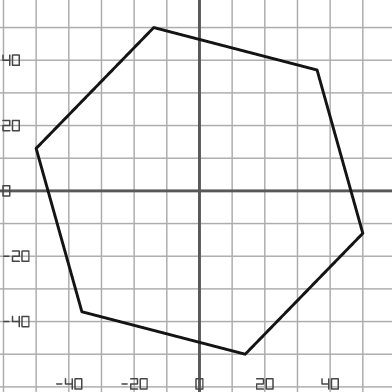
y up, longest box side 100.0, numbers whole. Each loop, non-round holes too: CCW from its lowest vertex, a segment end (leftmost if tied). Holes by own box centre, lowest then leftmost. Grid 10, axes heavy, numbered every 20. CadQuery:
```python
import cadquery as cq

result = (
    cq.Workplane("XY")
    .moveTo(14.0, -50.0)
    .lineTo(50.0, -13.0)
    .lineTo(36.0, 37.0)
    .lineTo(-14.0, 50.0)
    .lineTo(-50.0, 13.0)
    .lineTo(-36.0, -37.0)
    .close()
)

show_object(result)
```